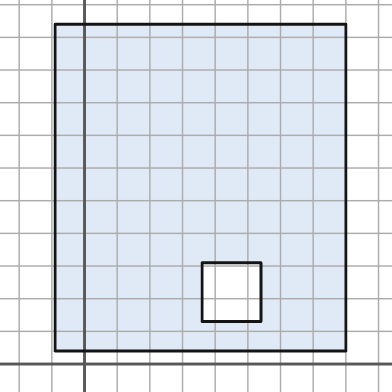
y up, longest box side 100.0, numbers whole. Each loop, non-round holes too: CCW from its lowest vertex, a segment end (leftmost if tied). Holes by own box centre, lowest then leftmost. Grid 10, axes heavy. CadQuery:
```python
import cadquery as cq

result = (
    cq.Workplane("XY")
    .moveTo(-9.0, 4.0)
    .lineTo(80.0, 4.0)
    .lineTo(80.0, 104.0)
    .lineTo(-9.0, 104.0)
    .close()
    .moveTo(36.0, 13.0)
    .lineTo(54.0, 13.0)
    .lineTo(54.0, 31.0)
    .lineTo(36.0, 31.0)
    .close()
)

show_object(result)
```